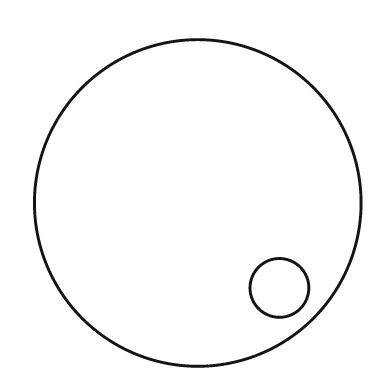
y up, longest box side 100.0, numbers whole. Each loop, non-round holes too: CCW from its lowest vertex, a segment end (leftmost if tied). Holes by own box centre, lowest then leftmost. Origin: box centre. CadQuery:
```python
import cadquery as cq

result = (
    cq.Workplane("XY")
    .moveTo(0.0, 0.0)
    .circle(50.0)
    .moveTo(25.0, -26.0)
    .circle(9.0)
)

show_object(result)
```